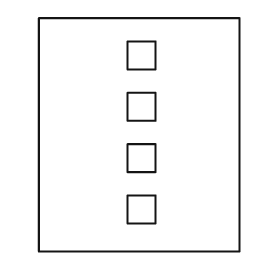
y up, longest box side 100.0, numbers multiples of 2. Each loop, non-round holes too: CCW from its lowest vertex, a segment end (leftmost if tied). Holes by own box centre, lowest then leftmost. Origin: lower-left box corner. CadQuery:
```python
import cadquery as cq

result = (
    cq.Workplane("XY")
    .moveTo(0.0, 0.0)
    .lineTo(86.0, 0.0)
    .lineTo(86.0, 100.0)
    .lineTo(0.0, 100.0)
    .close()
    .moveTo(38.0, 12.0)
    .lineTo(50.0, 12.0)
    .lineTo(50.0, 24.0)
    .lineTo(38.0, 24.0)
    .close()
    .moveTo(38.0, 34.0)
    .lineTo(50.0, 34.0)
    .lineTo(50.0, 46.0)
    .lineTo(38.0, 46.0)
    .close()
    .moveTo(38.0, 56.0)
    .lineTo(50.0, 56.0)
    .lineTo(50.0, 68.0)
    .lineTo(38.0, 68.0)
    .close()
    .moveTo(38.0, 78.0)
    .lineTo(50.0, 78.0)
    .lineTo(50.0, 90.0)
    .lineTo(38.0, 90.0)
    .close()
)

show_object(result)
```